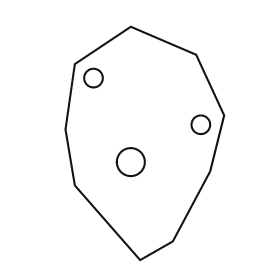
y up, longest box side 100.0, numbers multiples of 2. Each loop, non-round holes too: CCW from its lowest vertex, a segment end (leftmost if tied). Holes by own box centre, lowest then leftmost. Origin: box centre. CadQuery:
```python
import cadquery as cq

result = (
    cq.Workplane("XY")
    .moveTo(-2.0, -50.0)
    .lineTo(12.0, -42.0)
    .lineTo(28.0, -12.0)
    .lineTo(34.0, 12.0)
    .lineTo(22.0, 38.0)
    .lineTo(-6.0, 50.0)
    .lineTo(-30.0, 34.0)
    .lineTo(-34.0, 6.0)
    .lineTo(-30.0, -18.0)
    .close()
    .moveTo(-6.0, -8.0)
    .circle(6.0)
    .moveTo(24.0, 8.0)
    .circle(4.0)
    .moveTo(-22.0, 28.0)
    .circle(4.0)
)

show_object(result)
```